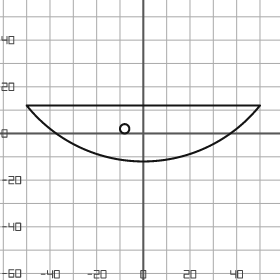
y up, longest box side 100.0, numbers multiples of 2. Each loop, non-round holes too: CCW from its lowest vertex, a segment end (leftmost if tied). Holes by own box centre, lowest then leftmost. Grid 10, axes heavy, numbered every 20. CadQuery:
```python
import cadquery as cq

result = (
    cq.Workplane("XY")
    .moveTo(-50.0, 12.0)
    .threePointArc((0.0, -12.0), (50.0, 12.0))
    .close()
    .moveTo(-8.0, 2.0)
    .circle(2.0)
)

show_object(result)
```